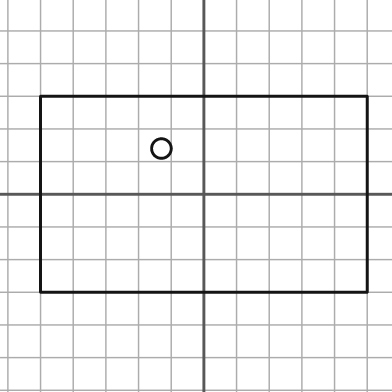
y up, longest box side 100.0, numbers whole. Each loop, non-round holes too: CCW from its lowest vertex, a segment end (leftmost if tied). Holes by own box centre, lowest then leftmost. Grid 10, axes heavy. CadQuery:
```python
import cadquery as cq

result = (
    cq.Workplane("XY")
    .moveTo(-50.0, -30.0)
    .lineTo(50.0, -30.0)
    .lineTo(50.0, 30.0)
    .lineTo(-50.0, 30.0)
    .close()
    .moveTo(-13.0, 14.0)
    .circle(3.0)
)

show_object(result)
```